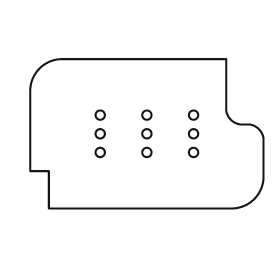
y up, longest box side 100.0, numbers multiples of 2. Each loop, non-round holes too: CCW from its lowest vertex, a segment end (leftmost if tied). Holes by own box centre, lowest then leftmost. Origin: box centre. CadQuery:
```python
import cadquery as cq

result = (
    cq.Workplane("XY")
    .moveTo(-42.0, -32.0)
    .lineTo(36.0, -32.0)
    .threePointArc((46.0, -28.0), (50.0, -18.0))
    .lineTo(50.0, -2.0)
    .threePointArc((48.0, 2.0), (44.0, 4.0))
    .lineTo(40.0, 4.0)
    .threePointArc((36.0, 6.0), (34.0, 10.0))
    .lineTo(34.0, 32.0)
    .lineTo(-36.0, 32.0)
    .threePointArc((-46.0, 28.0), (-50.0, 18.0))
    .lineTo(-50.0, -16.0)
    .lineTo(-42.0, -16.0)
    .close()
    .moveTo(-20.0, -8.0)
    .circle(2.0)
    .moveTo(0.0, -8.0)
    .circle(2.0)
    .moveTo(20.0, -8.0)
    .circle(2.0)
    .moveTo(-20.0, 0.0)
    .circle(2.0)
    .moveTo(0.0, 0.0)
    .circle(2.0)
    .moveTo(20.0, 0.0)
    .circle(2.0)
    .moveTo(-20.0, 8.0)
    .circle(2.0)
    .moveTo(0.0, 8.0)
    .circle(2.0)
    .moveTo(20.0, 8.0)
    .circle(2.0)
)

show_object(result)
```